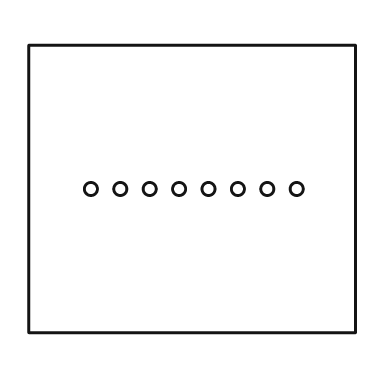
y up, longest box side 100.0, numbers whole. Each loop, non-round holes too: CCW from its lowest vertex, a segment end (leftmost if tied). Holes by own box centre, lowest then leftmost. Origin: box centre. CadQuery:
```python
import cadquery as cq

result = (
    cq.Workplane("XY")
    .moveTo(-50.0, -44.0)
    .lineTo(50.0, -44.0)
    .lineTo(50.0, 44.0)
    .lineTo(-50.0, 44.0)
    .close()
    .moveTo(-31.0, 0.0)
    .circle(2.0)
    .moveTo(-22.0, 0.0)
    .circle(2.0)
    .moveTo(-13.0, 0.0)
    .circle(2.0)
    .moveTo(-4.0, 0.0)
    .circle(2.0)
    .moveTo(5.0, 0.0)
    .circle(2.0)
    .moveTo(14.0, 0.0)
    .circle(2.0)
    .moveTo(23.0, 0.0)
    .circle(2.0)
    .moveTo(32.0, 0.0)
    .circle(2.0)
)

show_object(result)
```